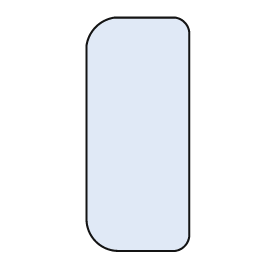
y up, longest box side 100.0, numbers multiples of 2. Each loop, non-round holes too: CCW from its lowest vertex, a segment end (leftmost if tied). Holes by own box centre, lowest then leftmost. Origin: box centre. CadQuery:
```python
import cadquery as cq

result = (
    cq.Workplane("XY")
    .moveTo(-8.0, -50.0)
    .lineTo(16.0, -50.0)
    .threePointArc((20.0, -48.0), (22.0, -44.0))
    .lineTo(22.0, 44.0)
    .threePointArc((20.0, 48.0), (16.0, 50.0))
    .lineTo(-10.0, 50.0)
    .threePointArc((-18.0, 46.0), (-22.0, 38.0))
    .lineTo(-22.0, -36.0)
    .threePointArc((-18.0, -46.0), (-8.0, -50.0))
    .close()
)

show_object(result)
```